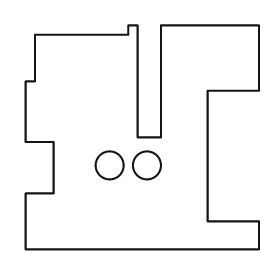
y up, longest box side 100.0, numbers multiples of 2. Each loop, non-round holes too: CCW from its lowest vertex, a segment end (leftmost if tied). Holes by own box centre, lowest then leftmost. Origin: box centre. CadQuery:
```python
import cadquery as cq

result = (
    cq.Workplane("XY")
    .moveTo(-50.0, -48.0)
    .lineTo(50.0, -48.0)
    .lineTo(50.0, -36.0)
    .lineTo(28.0, -36.0)
    .lineTo(28.0, 20.0)
    .lineTo(50.0, 20.0)
    .lineTo(50.0, 48.0)
    .lineTo(8.0, 48.0)
    .lineTo(8.0, 0.0)
    .lineTo(-2.0, 0.0)
    .lineTo(-2.0, 48.0)
    .lineTo(-6.0, 48.0)
    .lineTo(-6.0, 44.0)
    .lineTo(-46.0, 44.0)
    .lineTo(-46.0, 24.0)
    .lineTo(-50.0, 24.0)
    .lineTo(-50.0, -2.0)
    .lineTo(-38.0, -2.0)
    .lineTo(-38.0, -24.0)
    .lineTo(-50.0, -24.0)
    .close()
    .moveTo(-14.0, -12.0)
    .circle(6.0)
    .moveTo(2.0, -12.0)
    .circle(6.0)
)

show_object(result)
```